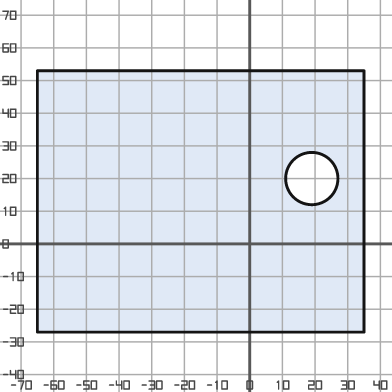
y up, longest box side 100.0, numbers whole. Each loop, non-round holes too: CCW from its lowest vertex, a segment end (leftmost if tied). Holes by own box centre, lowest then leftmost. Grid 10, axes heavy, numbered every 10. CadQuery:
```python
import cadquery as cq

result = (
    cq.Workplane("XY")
    .moveTo(-65.0, -27.0)
    .lineTo(35.0, -27.0)
    .lineTo(35.0, 53.0)
    .lineTo(-65.0, 53.0)
    .close()
    .moveTo(19.0, 20.0)
    .circle(8.0)
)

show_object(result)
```